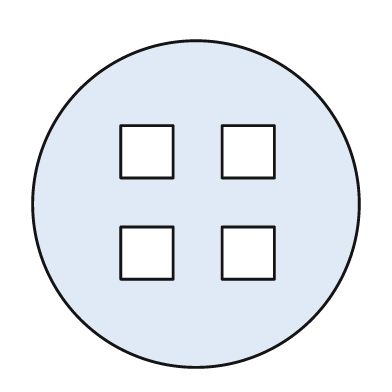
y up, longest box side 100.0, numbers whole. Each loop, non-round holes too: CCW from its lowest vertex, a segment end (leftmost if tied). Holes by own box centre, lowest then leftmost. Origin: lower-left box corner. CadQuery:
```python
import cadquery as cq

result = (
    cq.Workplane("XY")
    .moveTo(50.0, 50.0)
    .circle(50.0)
    .moveTo(27.0, 27.0)
    .lineTo(43.0, 27.0)
    .lineTo(43.0, 43.0)
    .lineTo(27.0, 43.0)
    .close()
    .moveTo(58.0, 27.0)
    .lineTo(74.0, 27.0)
    .lineTo(74.0, 43.0)
    .lineTo(58.0, 43.0)
    .close()
    .moveTo(27.0, 58.0)
    .lineTo(43.0, 58.0)
    .lineTo(43.0, 74.0)
    .lineTo(27.0, 74.0)
    .close()
    .moveTo(58.0, 58.0)
    .lineTo(74.0, 58.0)
    .lineTo(74.0, 74.0)
    .lineTo(58.0, 74.0)
    .close()
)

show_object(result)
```